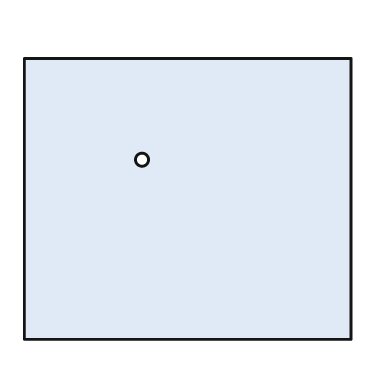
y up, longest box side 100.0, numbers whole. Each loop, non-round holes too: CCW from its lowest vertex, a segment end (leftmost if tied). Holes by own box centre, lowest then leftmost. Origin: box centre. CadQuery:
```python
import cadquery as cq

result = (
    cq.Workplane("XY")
    .moveTo(-50.0, -43.0)
    .lineTo(50.0, -43.0)
    .lineTo(50.0, 43.0)
    .lineTo(-50.0, 43.0)
    .close()
    .moveTo(-14.0, 12.0)
    .circle(2.0)
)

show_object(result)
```